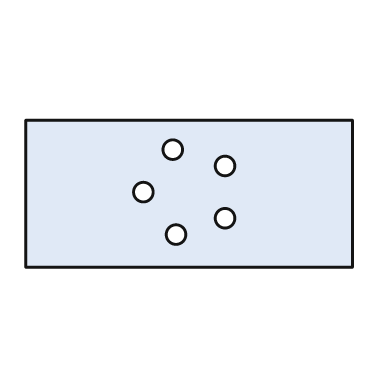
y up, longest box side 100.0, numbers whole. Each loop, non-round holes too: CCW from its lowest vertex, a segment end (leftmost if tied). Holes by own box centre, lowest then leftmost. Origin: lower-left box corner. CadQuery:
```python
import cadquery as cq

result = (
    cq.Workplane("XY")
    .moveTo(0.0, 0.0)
    .lineTo(100.0, 0.0)
    .lineTo(100.0, 45.0)
    .lineTo(0.0, 45.0)
    .close()
    .moveTo(46.0, 10.0)
    .circle(3.0)
    .moveTo(61.0, 15.0)
    .circle(3.0)
    .moveTo(36.0, 23.0)
    .circle(3.0)
    .moveTo(61.0, 31.0)
    .circle(3.0)
    .moveTo(45.0, 36.0)
    .circle(3.0)
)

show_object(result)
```